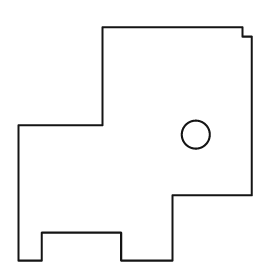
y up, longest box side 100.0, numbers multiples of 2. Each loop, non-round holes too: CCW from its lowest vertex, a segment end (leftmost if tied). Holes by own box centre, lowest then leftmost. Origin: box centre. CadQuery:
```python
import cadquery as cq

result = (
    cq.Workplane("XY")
    .moveTo(-50.0, -50.0)
    .lineTo(-40.0, -50.0)
    .lineTo(-40.0, -38.0)
    .lineTo(-6.0, -38.0)
    .lineTo(-6.0, -50.0)
    .lineTo(16.0, -50.0)
    .lineTo(16.0, -22.0)
    .lineTo(50.0, -22.0)
    .lineTo(50.0, 46.0)
    .lineTo(46.0, 46.0)
    .lineTo(46.0, 50.0)
    .lineTo(-14.0, 50.0)
    .lineTo(-14.0, 8.0)
    .lineTo(-50.0, 8.0)
    .close()
    .moveTo(26.0, 4.0)
    .circle(6.0)
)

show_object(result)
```